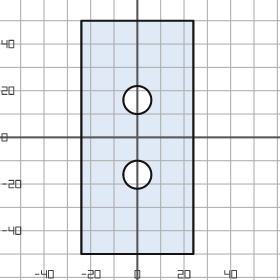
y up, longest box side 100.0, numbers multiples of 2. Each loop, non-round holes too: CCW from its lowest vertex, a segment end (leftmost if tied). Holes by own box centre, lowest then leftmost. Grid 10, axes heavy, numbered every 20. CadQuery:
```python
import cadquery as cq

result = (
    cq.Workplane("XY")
    .moveTo(-24.0, -50.0)
    .lineTo(24.0, -50.0)
    .lineTo(24.0, 50.0)
    .lineTo(-24.0, 50.0)
    .close()
    .moveTo(0.0, -16.0)
    .circle(6.0)
    .moveTo(0.0, 16.0)
    .circle(6.0)
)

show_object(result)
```